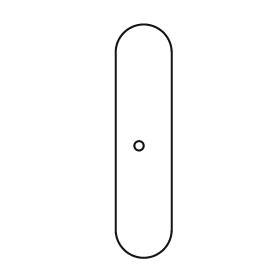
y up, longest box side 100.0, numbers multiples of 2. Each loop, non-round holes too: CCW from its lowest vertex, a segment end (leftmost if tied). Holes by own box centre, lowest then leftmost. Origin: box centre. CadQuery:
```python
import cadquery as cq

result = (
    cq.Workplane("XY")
    .moveTo(-12.0, -38.0)
    .threePointArc((0.0, -50.0), (12.0, -38.0))
    .lineTo(12.0, 38.0)
    .threePointArc((0.0, 50.0), (-12.0, 38.0))
    .close()
    .moveTo(-2.0, -2.0)
    .circle(2.0)
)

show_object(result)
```